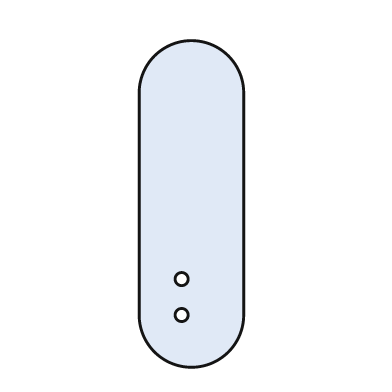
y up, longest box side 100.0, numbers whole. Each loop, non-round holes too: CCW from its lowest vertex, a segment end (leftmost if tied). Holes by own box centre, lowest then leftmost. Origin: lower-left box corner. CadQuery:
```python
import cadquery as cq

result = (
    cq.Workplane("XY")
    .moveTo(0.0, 16.0)
    .threePointArc((16.0, 0.0), (32.0, 16.0))
    .lineTo(32.0, 84.0)
    .threePointArc((16.0, 100.0), (0.0, 84.0))
    .close()
    .moveTo(13.0, 16.0)
    .circle(2.0)
    .moveTo(13.0, 27.0)
    .circle(2.0)
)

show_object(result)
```